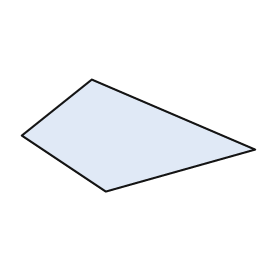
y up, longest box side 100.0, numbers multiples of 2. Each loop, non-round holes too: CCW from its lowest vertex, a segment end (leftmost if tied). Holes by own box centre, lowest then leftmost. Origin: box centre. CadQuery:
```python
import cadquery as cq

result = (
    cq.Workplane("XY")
    .moveTo(-14.0, -24.0)
    .lineTo(50.0, -6.0)
    .lineTo(-20.0, 24.0)
    .lineTo(-50.0, 0.0)
    .close()
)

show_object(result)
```